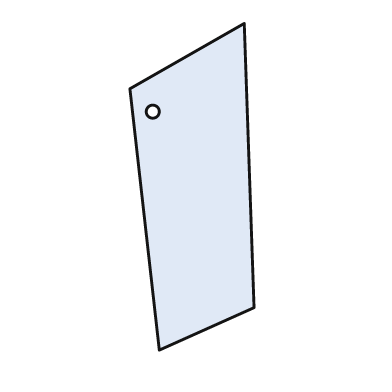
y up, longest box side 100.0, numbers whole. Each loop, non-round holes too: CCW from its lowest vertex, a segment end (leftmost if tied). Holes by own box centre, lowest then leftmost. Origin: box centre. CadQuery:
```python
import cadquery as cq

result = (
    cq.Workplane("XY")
    .moveTo(-10.0, -50.0)
    .lineTo(19.0, -37.0)
    .lineTo(16.0, 50.0)
    .lineTo(-19.0, 30.0)
    .close()
    .moveTo(-12.0, 23.0)
    .circle(2.0)
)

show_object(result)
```